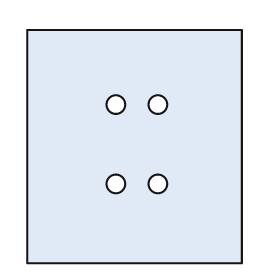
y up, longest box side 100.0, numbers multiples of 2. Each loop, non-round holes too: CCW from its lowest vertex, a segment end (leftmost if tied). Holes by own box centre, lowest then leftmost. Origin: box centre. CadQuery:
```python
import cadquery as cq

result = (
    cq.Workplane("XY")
    .moveTo(-46.0, -50.0)
    .lineTo(46.0, -50.0)
    .lineTo(46.0, 50.0)
    .lineTo(-46.0, 50.0)
    .close()
    .moveTo(-8.0, -16.0)
    .circle(4.0)
    .moveTo(10.0, -16.0)
    .circle(4.0)
    .moveTo(-8.0, 18.0)
    .circle(4.0)
    .moveTo(10.0, 18.0)
    .circle(4.0)
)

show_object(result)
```